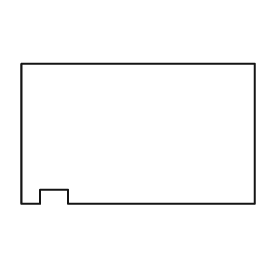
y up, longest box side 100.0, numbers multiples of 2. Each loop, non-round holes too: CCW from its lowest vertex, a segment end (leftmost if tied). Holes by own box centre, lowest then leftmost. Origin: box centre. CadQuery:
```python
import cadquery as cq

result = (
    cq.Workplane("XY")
    .moveTo(-50.0, -30.0)
    .lineTo(-42.0, -30.0)
    .lineTo(-42.0, -24.0)
    .lineTo(-30.0, -24.0)
    .lineTo(-30.0, -30.0)
    .lineTo(50.0, -30.0)
    .lineTo(50.0, 30.0)
    .lineTo(-50.0, 30.0)
    .close()
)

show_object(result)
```